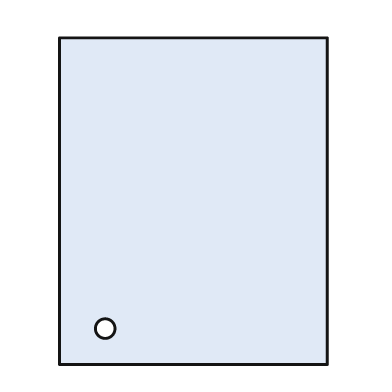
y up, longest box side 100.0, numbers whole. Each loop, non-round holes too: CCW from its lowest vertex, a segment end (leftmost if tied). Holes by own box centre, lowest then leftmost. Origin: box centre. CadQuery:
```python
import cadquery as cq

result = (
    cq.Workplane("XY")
    .moveTo(-41.0, -50.0)
    .lineTo(41.0, -50.0)
    .lineTo(41.0, 50.0)
    .lineTo(-41.0, 50.0)
    .close()
    .moveTo(-27.0, -39.0)
    .circle(3.0)
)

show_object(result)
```